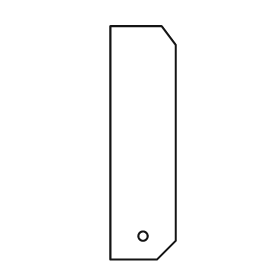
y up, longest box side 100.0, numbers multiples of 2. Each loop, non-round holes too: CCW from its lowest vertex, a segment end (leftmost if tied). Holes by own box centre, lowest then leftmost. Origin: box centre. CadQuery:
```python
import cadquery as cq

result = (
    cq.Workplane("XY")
    .moveTo(-14.0, -50.0)
    .lineTo(6.0, -50.0)
    .lineTo(14.0, -42.0)
    .lineTo(14.0, 42.0)
    .lineTo(8.0, 50.0)
    .lineTo(-14.0, 50.0)
    .close()
    .moveTo(0.0, -40.0)
    .circle(2.0)
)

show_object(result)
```